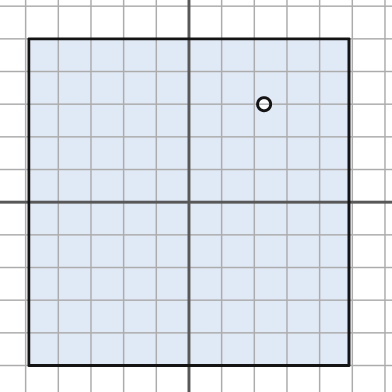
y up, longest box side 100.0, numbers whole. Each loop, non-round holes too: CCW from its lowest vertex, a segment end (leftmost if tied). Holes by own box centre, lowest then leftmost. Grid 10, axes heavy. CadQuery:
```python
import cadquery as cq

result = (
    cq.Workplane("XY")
    .moveTo(-49.0, -50.0)
    .lineTo(49.0, -50.0)
    .lineTo(49.0, 50.0)
    .lineTo(-49.0, 50.0)
    .close()
    .moveTo(23.0, 30.0)
    .circle(2.0)
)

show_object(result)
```